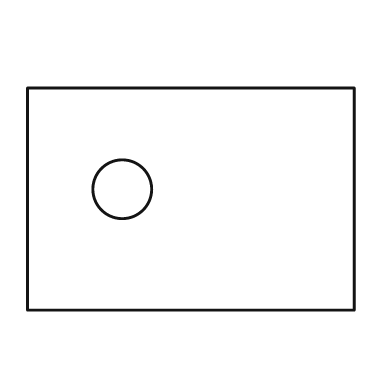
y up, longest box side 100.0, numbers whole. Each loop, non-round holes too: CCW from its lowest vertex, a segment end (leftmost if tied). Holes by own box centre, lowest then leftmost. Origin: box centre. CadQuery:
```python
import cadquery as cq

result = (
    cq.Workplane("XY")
    .moveTo(-50.0, -34.0)
    .lineTo(50.0, -34.0)
    .lineTo(50.0, 34.0)
    .lineTo(-50.0, 34.0)
    .close()
    .moveTo(-21.0, 3.0)
    .circle(9.0)
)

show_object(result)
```